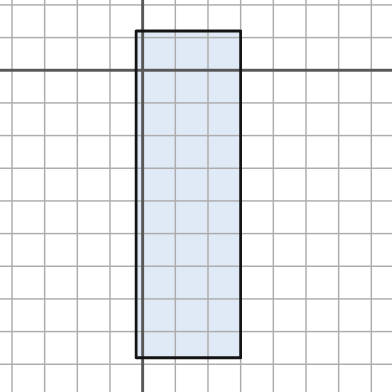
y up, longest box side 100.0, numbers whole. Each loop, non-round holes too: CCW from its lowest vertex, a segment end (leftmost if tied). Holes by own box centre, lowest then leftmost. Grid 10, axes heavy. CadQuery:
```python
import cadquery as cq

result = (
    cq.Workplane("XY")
    .moveTo(-2.0, -88.0)
    .lineTo(30.0, -88.0)
    .lineTo(30.0, 12.0)
    .lineTo(-2.0, 12.0)
    .close()
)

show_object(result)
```